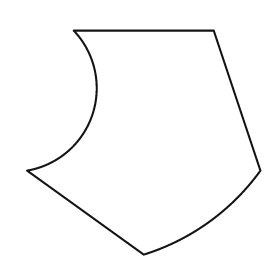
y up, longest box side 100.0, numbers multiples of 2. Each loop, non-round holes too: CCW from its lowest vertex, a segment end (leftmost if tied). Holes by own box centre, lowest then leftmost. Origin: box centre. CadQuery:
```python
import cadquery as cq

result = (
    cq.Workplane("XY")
    .moveTo(0.0, -48.0)
    .threePointArc((28.0, -34.0), (50.0, -12.0))
    .lineTo(30.0, 48.0)
    .lineTo(-30.0, 48.0)
    .threePointArc((-22.0, 12.0), (-50.0, -12.0))
    .close()
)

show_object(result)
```